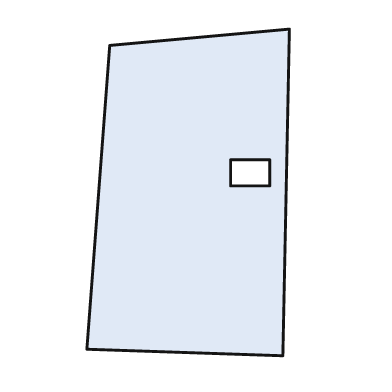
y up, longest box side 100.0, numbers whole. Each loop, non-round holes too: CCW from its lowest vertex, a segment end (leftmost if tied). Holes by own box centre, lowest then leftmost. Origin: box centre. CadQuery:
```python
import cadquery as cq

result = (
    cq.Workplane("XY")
    .moveTo(29.0, -50.0)
    .lineTo(31.0, 50.0)
    .lineTo(-24.0, 45.0)
    .lineTo(-31.0, -48.0)
    .close()
    .moveTo(13.0, 2.0)
    .lineTo(25.0, 2.0)
    .lineTo(25.0, 10.0)
    .lineTo(13.0, 10.0)
    .close()
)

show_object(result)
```